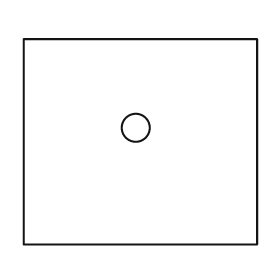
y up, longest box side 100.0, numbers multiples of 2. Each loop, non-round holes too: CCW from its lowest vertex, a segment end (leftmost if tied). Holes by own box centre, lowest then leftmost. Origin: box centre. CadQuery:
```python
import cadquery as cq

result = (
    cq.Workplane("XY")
    .moveTo(-50.0, -44.0)
    .lineTo(50.0, -44.0)
    .lineTo(50.0, 44.0)
    .lineTo(-50.0, 44.0)
    .close()
    .moveTo(-2.0, 6.0)
    .circle(6.0)
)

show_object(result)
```